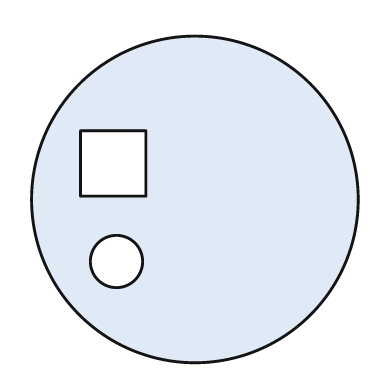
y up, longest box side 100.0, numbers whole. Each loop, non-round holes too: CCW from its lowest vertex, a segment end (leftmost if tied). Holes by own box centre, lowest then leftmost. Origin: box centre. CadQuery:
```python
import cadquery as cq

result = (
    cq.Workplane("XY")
    .moveTo(0.0, 0.0)
    .circle(50.0)
    .moveTo(-24.0, -19.0)
    .circle(8.0)
    .moveTo(-35.0, 1.0)
    .lineTo(-15.0, 1.0)
    .lineTo(-15.0, 21.0)
    .lineTo(-35.0, 21.0)
    .close()
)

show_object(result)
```